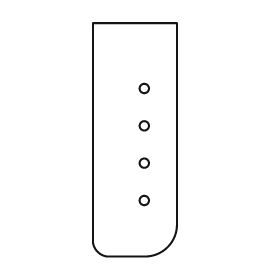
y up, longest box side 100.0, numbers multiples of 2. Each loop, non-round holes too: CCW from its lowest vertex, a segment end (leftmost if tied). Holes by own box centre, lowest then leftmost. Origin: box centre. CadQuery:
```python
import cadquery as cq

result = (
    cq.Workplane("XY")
    .moveTo(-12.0, -50.0)
    .lineTo(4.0, -50.0)
    .threePointArc((14.0, -46.0), (18.0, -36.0))
    .lineTo(18.0, 50.0)
    .lineTo(-18.0, 50.0)
    .lineTo(-18.0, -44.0)
    .threePointArc((-16.0, -48.0), (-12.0, -50.0))
    .close()
    .moveTo(4.0, -26.0)
    .circle(2.0)
    .moveTo(4.0, -10.0)
    .circle(2.0)
    .moveTo(4.0, 6.0)
    .circle(2.0)
    .moveTo(4.0, 22.0)
    .circle(2.0)
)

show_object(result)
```